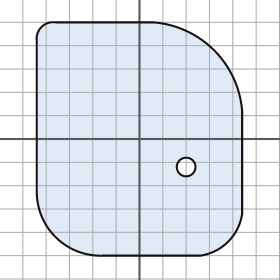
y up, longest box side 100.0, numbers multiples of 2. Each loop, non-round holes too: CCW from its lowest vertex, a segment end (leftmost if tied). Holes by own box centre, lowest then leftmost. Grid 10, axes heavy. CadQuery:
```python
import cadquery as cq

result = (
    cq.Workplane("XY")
    .moveTo(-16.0, -50.0)
    .lineTo(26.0, -50.0)
    .threePointArc((38.0, -44.0), (44.0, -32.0))
    .lineTo(44.0, 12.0)
    .threePointArc((32.0, 38.0), (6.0, 50.0))
    .lineTo(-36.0, 50.0)
    .threePointArc((-42.0, 48.0), (-44.0, 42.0))
    .lineTo(-44.0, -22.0)
    .threePointArc((-36.0, -42.0), (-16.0, -50.0))
    .close()
    .moveTo(20.0, -12.0)
    .circle(4.0)
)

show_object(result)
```